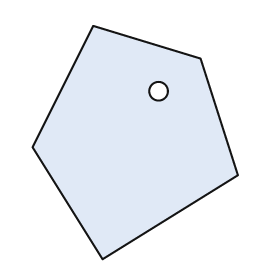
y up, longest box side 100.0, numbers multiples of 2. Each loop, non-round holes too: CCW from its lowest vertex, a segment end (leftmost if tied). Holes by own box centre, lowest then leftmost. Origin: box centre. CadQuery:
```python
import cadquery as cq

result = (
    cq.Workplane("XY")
    .moveTo(-14.0, -50.0)
    .lineTo(44.0, -14.0)
    .lineTo(28.0, 36.0)
    .lineTo(-18.0, 50.0)
    .lineTo(-44.0, -2.0)
    .close()
    .moveTo(10.0, 22.0)
    .circle(4.0)
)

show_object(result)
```